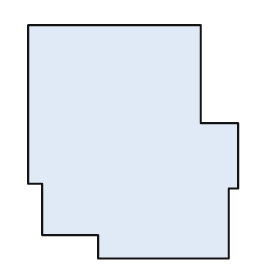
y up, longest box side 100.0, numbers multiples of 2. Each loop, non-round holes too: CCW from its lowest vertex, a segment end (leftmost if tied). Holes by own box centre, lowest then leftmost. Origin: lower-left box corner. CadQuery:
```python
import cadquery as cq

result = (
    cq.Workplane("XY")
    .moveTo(30.0, 0.0)
    .lineTo(86.0, 0.0)
    .lineTo(86.0, 30.0)
    .lineTo(90.0, 30.0)
    .lineTo(90.0, 58.0)
    .lineTo(74.0, 58.0)
    .lineTo(74.0, 100.0)
    .lineTo(0.0, 100.0)
    .lineTo(0.0, 32.0)
    .lineTo(6.0, 32.0)
    .lineTo(6.0, 10.0)
    .lineTo(30.0, 10.0)
    .close()
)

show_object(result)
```